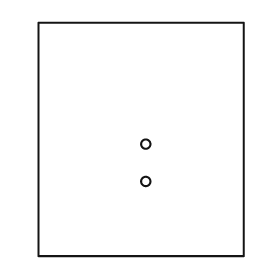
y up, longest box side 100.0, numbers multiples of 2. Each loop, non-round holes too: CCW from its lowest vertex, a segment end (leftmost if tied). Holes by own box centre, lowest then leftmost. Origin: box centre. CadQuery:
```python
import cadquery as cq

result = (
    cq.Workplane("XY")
    .moveTo(-44.0, -50.0)
    .lineTo(44.0, -50.0)
    .lineTo(44.0, 50.0)
    .lineTo(-44.0, 50.0)
    .close()
    .moveTo(2.0, -18.0)
    .circle(2.0)
    .moveTo(2.0, -2.0)
    .circle(2.0)
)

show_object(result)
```